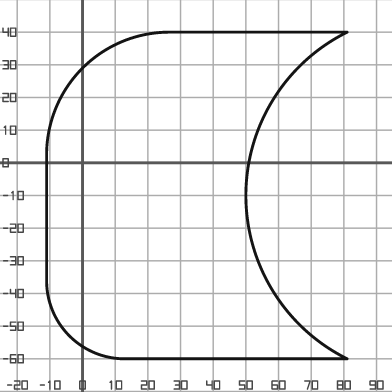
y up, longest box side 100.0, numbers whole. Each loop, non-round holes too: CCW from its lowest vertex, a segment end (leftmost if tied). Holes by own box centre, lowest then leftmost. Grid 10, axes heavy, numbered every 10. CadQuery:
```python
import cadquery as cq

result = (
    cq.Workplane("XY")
    .moveTo(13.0, -60.0)
    .lineTo(81.0, -60.0)
    .threePointArc((50.0, -10.0), (81.0, 40.0))
    .lineTo(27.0, 40.0)
    .threePointArc((0.0, 29.0), (-11.0, 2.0))
    .lineTo(-11.0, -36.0)
    .threePointArc((-4.0, -53.0), (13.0, -60.0))
    .close()
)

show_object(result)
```